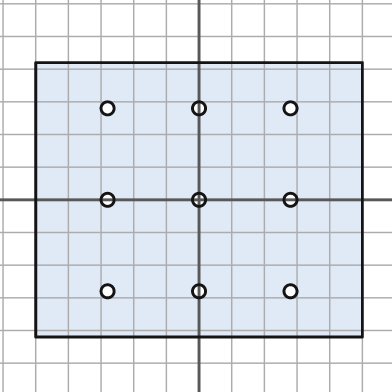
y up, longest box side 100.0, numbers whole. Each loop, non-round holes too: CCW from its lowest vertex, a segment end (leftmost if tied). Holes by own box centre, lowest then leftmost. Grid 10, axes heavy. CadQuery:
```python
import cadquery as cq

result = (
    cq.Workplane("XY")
    .moveTo(-50.0, -42.0)
    .lineTo(50.0, -42.0)
    .lineTo(50.0, 42.0)
    .lineTo(-50.0, 42.0)
    .close()
    .moveTo(-28.0, -28.0)
    .circle(2.0)
    .moveTo(0.0, -28.0)
    .circle(2.0)
    .moveTo(28.0, -28.0)
    .circle(2.0)
    .moveTo(-28.0, 0.0)
    .circle(2.0)
    .moveTo(0.0, 0.0)
    .circle(2.0)
    .moveTo(28.0, 0.0)
    .circle(2.0)
    .moveTo(-28.0, 28.0)
    .circle(2.0)
    .moveTo(0.0, 28.0)
    .circle(2.0)
    .moveTo(28.0, 28.0)
    .circle(2.0)
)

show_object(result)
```